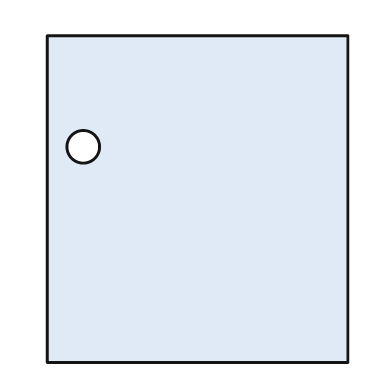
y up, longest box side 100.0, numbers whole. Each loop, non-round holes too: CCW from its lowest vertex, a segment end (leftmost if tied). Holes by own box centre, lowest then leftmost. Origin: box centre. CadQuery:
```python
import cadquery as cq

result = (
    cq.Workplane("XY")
    .moveTo(-46.0, -50.0)
    .lineTo(46.0, -50.0)
    .lineTo(46.0, 50.0)
    .lineTo(-46.0, 50.0)
    .close()
    .moveTo(-35.0, 16.0)
    .circle(5.0)
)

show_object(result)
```